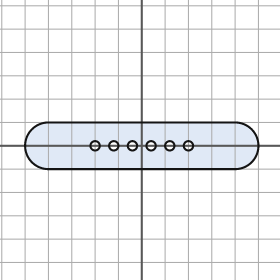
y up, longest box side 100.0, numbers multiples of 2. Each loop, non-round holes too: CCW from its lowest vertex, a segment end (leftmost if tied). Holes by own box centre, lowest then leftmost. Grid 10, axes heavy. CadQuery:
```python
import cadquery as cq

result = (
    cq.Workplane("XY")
    .moveTo(-40.0, -10.0)
    .lineTo(40.0, -10.0)
    .threePointArc((50.0, 0.0), (40.0, 10.0))
    .lineTo(-40.0, 10.0)
    .threePointArc((-50.0, 0.0), (-40.0, -10.0))
    .close()
    .moveTo(-20.0, 0.0)
    .circle(2.0)
    .moveTo(-12.0, 0.0)
    .circle(2.0)
    .moveTo(-4.0, 0.0)
    .circle(2.0)
    .moveTo(4.0, 0.0)
    .circle(2.0)
    .moveTo(12.0, 0.0)
    .circle(2.0)
    .moveTo(20.0, 0.0)
    .circle(2.0)
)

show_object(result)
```